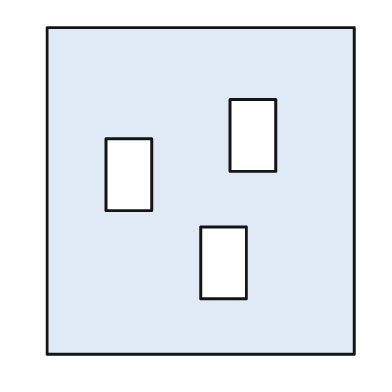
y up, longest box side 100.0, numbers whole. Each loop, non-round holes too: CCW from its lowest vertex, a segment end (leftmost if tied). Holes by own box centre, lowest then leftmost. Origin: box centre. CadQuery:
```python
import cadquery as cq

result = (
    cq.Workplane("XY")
    .moveTo(-47.0, -50.0)
    .lineTo(47.0, -50.0)
    .lineTo(47.0, 50.0)
    .lineTo(-47.0, 50.0)
    .close()
    .moveTo(0.0, -33.0)
    .lineTo(14.0, -33.0)
    .lineTo(14.0, -11.0)
    .lineTo(0.0, -11.0)
    .close()
    .moveTo(-29.0, -6.0)
    .lineTo(-15.0, -6.0)
    .lineTo(-15.0, 16.0)
    .lineTo(-29.0, 16.0)
    .close()
    .moveTo(9.0, 6.0)
    .lineTo(23.0, 6.0)
    .lineTo(23.0, 28.0)
    .lineTo(9.0, 28.0)
    .close()
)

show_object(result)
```